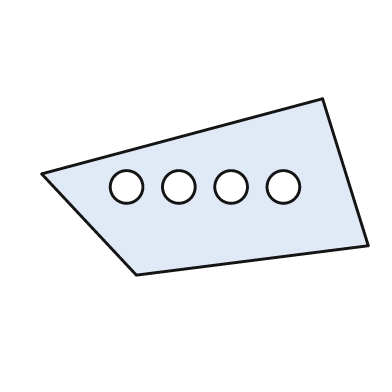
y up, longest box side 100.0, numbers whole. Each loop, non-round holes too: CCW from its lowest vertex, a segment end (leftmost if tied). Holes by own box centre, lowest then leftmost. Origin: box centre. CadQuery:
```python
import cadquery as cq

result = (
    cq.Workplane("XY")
    .moveTo(-21.0, -27.0)
    .lineTo(50.0, -18.0)
    .lineTo(36.0, 27.0)
    .lineTo(-50.0, 4.0)
    .close()
    .moveTo(-24.0, 0.0)
    .circle(5.0)
    .moveTo(-8.0, 0.0)
    .circle(5.0)
    .moveTo(8.0, 0.0)
    .circle(5.0)
    .moveTo(24.0, 0.0)
    .circle(5.0)
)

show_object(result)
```